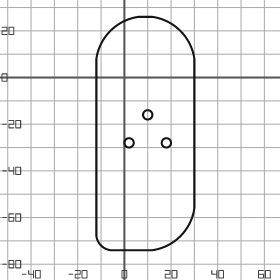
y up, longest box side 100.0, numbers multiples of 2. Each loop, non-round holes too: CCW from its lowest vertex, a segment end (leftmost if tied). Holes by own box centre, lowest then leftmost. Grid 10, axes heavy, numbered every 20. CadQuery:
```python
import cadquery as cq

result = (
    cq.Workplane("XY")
    .moveTo(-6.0, -74.0)
    .lineTo(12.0, -74.0)
    .threePointArc((24.0, -68.0), (30.0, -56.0))
    .lineTo(30.0, 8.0)
    .threePointArc((24.0, 20.0), (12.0, 26.0))
    .lineTo(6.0, 26.0)
    .threePointArc((-6.0, 20.0), (-12.0, 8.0))
    .lineTo(-12.0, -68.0)
    .threePointArc((-10.0, -72.0), (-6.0, -74.0))
    .close()
    .moveTo(2.0, -28.0)
    .circle(2.0)
    .moveTo(18.0, -28.0)
    .circle(2.0)
    .moveTo(10.0, -16.0)
    .circle(2.0)
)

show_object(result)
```